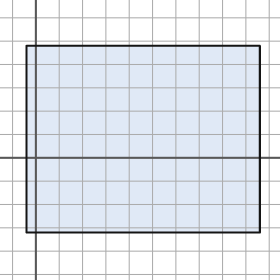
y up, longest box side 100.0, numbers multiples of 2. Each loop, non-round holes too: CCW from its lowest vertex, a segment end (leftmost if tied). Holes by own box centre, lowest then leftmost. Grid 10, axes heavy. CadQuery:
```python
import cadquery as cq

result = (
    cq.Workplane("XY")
    .moveTo(-4.0, -32.0)
    .lineTo(96.0, -32.0)
    .lineTo(96.0, 48.0)
    .lineTo(-4.0, 48.0)
    .close()
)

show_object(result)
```